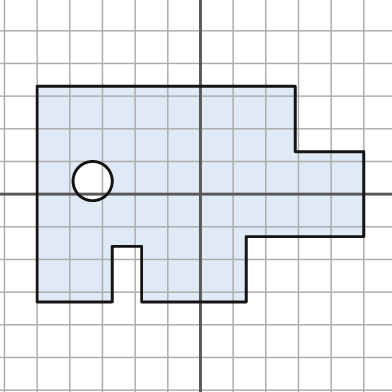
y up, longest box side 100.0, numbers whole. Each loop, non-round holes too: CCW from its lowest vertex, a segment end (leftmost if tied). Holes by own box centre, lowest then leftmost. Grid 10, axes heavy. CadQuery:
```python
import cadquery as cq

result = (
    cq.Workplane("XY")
    .moveTo(-50.0, -33.0)
    .lineTo(-27.0, -33.0)
    .lineTo(-27.0, -16.0)
    .lineTo(-18.0, -16.0)
    .lineTo(-18.0, -33.0)
    .lineTo(14.0, -33.0)
    .lineTo(14.0, -13.0)
    .lineTo(50.0, -13.0)
    .lineTo(50.0, 13.0)
    .lineTo(29.0, 13.0)
    .lineTo(29.0, 33.0)
    .lineTo(-50.0, 33.0)
    .close()
    .moveTo(-33.0, 4.0)
    .circle(6.0)
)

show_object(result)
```